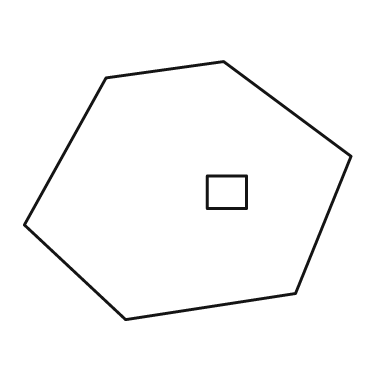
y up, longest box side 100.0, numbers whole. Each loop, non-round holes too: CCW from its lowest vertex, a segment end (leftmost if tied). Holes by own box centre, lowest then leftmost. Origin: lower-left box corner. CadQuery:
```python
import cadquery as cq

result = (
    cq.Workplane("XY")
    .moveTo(31.0, 0.0)
    .lineTo(83.0, 8.0)
    .lineTo(100.0, 50.0)
    .lineTo(61.0, 79.0)
    .lineTo(25.0, 74.0)
    .lineTo(0.0, 29.0)
    .close()
    .moveTo(56.0, 34.0)
    .lineTo(68.0, 34.0)
    .lineTo(68.0, 44.0)
    .lineTo(56.0, 44.0)
    .close()
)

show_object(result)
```